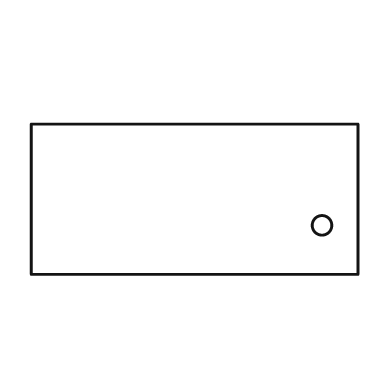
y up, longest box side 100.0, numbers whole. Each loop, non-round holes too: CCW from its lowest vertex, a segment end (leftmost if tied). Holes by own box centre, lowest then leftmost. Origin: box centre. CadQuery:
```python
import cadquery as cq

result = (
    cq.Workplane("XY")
    .moveTo(-50.0, -23.0)
    .lineTo(50.0, -23.0)
    .lineTo(50.0, 23.0)
    .lineTo(-50.0, 23.0)
    .close()
    .moveTo(39.0, -8.0)
    .circle(3.0)
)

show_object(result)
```